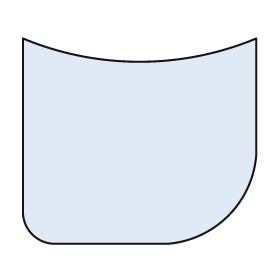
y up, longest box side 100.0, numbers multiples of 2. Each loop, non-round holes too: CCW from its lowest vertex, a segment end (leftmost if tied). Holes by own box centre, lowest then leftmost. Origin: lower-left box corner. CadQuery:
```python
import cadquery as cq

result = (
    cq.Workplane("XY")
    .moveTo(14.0, 0.0)
    .lineTo(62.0, 0.0)
    .threePointArc((88.0, 12.0), (100.0, 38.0))
    .lineTo(100.0, 88.0)
    .threePointArc((50.0, 78.0), (0.0, 88.0))
    .lineTo(0.0, 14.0)
    .threePointArc((4.0, 4.0), (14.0, 0.0))
    .close()
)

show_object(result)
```